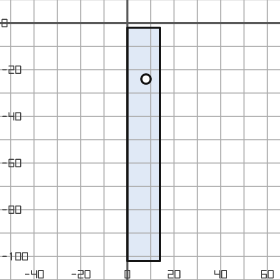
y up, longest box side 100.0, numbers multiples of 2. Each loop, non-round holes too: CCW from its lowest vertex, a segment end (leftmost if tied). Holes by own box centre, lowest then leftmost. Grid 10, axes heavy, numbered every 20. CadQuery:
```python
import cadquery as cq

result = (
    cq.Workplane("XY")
    .moveTo(0.0, -102.0)
    .lineTo(14.0, -102.0)
    .lineTo(14.0, -2.0)
    .lineTo(0.0, -2.0)
    .close()
    .moveTo(8.0, -24.0)
    .circle(2.0)
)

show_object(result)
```